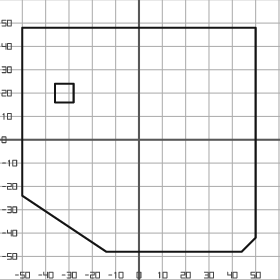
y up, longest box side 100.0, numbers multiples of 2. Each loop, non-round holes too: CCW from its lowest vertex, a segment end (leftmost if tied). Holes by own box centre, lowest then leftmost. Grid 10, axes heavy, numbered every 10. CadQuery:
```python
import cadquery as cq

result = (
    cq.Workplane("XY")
    .moveTo(-14.0, -48.0)
    .lineTo(44.0, -48.0)
    .lineTo(50.0, -42.0)
    .lineTo(50.0, 48.0)
    .lineTo(-50.0, 48.0)
    .lineTo(-50.0, -24.0)
    .close()
    .moveTo(-36.0, 16.0)
    .lineTo(-28.0, 16.0)
    .lineTo(-28.0, 24.0)
    .lineTo(-36.0, 24.0)
    .close()
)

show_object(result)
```